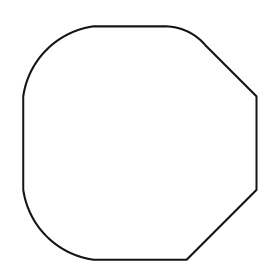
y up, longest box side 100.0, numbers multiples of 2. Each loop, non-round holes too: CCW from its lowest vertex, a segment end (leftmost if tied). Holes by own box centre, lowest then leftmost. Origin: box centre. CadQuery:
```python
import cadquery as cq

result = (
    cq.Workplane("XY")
    .moveTo(-20.0, -50.0)
    .lineTo(20.0, -50.0)
    .lineTo(50.0, -20.0)
    .lineTo(50.0, 20.0)
    .lineTo(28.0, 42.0)
    .threePointArc((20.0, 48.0), (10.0, 50.0))
    .lineTo(-20.0, 50.0)
    .threePointArc((-40.0, 40.0), (-50.0, 20.0))
    .lineTo(-50.0, -20.0)
    .threePointArc((-40.0, -40.0), (-20.0, -50.0))
    .close()
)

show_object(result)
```